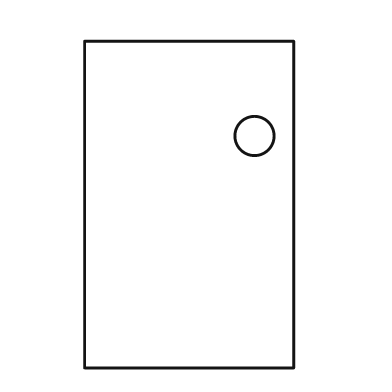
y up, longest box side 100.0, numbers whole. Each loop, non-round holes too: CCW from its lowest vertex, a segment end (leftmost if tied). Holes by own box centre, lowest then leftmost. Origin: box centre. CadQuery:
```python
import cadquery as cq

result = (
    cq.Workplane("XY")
    .moveTo(-32.0, -50.0)
    .lineTo(32.0, -50.0)
    .lineTo(32.0, 50.0)
    .lineTo(-32.0, 50.0)
    .close()
    .moveTo(20.0, 21.0)
    .circle(6.0)
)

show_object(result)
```